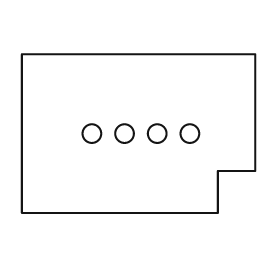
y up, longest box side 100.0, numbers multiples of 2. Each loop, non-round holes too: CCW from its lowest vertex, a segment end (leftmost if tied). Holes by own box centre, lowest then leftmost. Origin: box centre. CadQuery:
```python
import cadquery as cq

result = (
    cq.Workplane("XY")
    .moveTo(-50.0, -34.0)
    .lineTo(34.0, -34.0)
    .lineTo(34.0, -16.0)
    .lineTo(50.0, -16.0)
    .lineTo(50.0, 34.0)
    .lineTo(-50.0, 34.0)
    .close()
    .moveTo(-20.0, 0.0)
    .circle(4.0)
    .moveTo(-6.0, 0.0)
    .circle(4.0)
    .moveTo(8.0, 0.0)
    .circle(4.0)
    .moveTo(22.0, 0.0)
    .circle(4.0)
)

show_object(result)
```